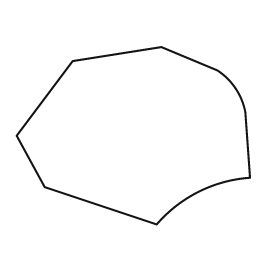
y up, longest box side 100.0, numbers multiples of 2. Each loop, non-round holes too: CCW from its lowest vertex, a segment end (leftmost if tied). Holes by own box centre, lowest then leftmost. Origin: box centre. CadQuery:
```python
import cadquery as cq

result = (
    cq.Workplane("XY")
    .moveTo(10.0, -38.0)
    .threePointArc((28.0, -24.0), (50.0, -18.0))
    .lineTo(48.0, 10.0)
    .threePointArc((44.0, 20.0), (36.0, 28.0))
    .lineTo(12.0, 38.0)
    .lineTo(-26.0, 32.0)
    .lineTo(-50.0, 0.0)
    .lineTo(-38.0, -22.0)
    .close()
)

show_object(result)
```